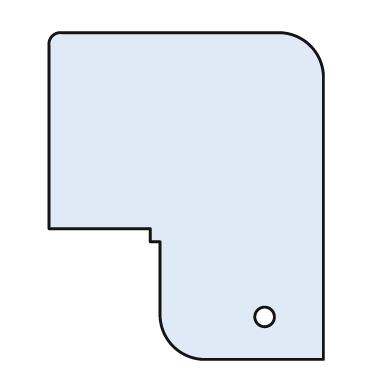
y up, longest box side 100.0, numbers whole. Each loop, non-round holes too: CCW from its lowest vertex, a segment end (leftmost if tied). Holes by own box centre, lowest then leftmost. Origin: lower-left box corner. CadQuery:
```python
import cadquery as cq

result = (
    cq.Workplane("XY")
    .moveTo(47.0, 0.0)
    .lineTo(84.0, 0.0)
    .lineTo(84.0, 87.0)
    .threePointArc((80.0, 96.0), (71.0, 100.0))
    .lineTo(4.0, 100.0)
    .threePointArc((1.0, 99.0), (0.0, 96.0))
    .lineTo(0.0, 40.0)
    .lineTo(31.0, 40.0)
    .lineTo(31.0, 36.0)
    .lineTo(34.0, 36.0)
    .lineTo(34.0, 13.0)
    .threePointArc((38.0, 4.0), (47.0, 0.0))
    .close()
    .moveTo(66.0, 13.0)
    .circle(3.0)
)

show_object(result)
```